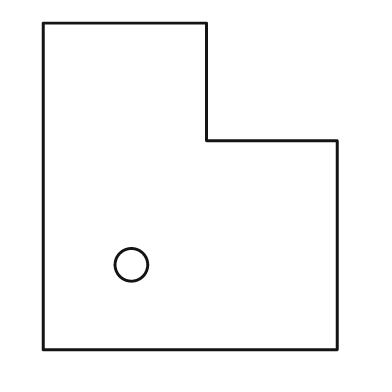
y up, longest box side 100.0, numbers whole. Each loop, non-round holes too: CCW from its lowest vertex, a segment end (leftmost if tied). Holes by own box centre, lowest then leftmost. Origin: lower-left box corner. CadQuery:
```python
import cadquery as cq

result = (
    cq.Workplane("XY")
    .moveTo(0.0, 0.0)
    .lineTo(90.0, 0.0)
    .lineTo(90.0, 64.0)
    .lineTo(50.0, 64.0)
    .lineTo(50.0, 100.0)
    .lineTo(0.0, 100.0)
    .close()
    .moveTo(27.0, 26.0)
    .circle(5.0)
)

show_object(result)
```